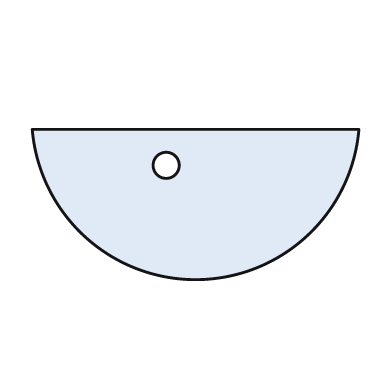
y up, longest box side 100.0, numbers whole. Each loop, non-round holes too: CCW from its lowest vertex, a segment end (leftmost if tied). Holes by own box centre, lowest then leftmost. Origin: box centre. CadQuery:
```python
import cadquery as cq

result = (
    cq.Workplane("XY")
    .moveTo(-50.0, 23.0)
    .threePointArc((0.0, -23.0), (50.0, 23.0))
    .close()
    .moveTo(-9.0, 12.0)
    .circle(4.0)
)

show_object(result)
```